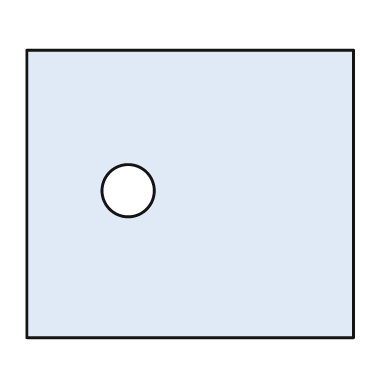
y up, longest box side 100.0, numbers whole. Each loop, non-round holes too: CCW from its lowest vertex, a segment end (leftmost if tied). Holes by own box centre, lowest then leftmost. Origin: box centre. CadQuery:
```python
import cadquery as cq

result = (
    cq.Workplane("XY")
    .moveTo(-50.0, -44.0)
    .lineTo(50.0, -44.0)
    .lineTo(50.0, 44.0)
    .lineTo(-50.0, 44.0)
    .close()
    .moveTo(-19.0, 1.0)
    .circle(8.0)
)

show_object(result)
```